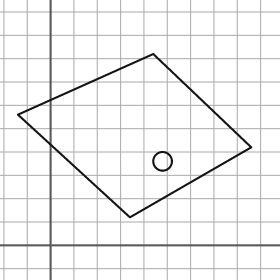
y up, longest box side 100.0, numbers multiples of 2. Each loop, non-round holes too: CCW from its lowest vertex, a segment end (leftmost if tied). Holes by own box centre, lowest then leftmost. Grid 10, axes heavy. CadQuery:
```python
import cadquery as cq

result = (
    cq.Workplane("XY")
    .moveTo(34.0, 12.0)
    .lineTo(86.0, 42.0)
    .lineTo(44.0, 82.0)
    .lineTo(-14.0, 56.0)
    .close()
    .moveTo(48.0, 36.0)
    .circle(4.0)
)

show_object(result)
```